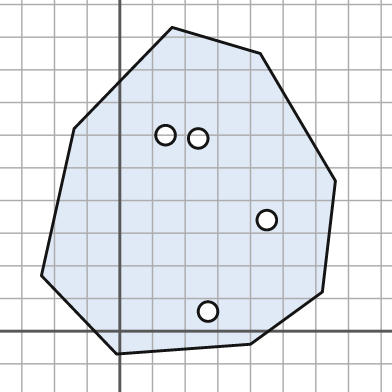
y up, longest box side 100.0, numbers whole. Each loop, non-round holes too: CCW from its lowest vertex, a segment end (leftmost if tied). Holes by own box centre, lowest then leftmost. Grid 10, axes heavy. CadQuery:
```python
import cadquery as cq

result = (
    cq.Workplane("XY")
    .moveTo(-1.0, -7.0)
    .lineTo(40.0, -4.0)
    .lineTo(62.0, 12.0)
    .lineTo(66.0, 46.0)
    .lineTo(43.0, 85.0)
    .lineTo(16.0, 93.0)
    .lineTo(-14.0, 62.0)
    .lineTo(-24.0, 17.0)
    .close()
    .moveTo(27.0, 6.0)
    .circle(3.0)
    .moveTo(45.0, 34.0)
    .circle(3.0)
    .moveTo(24.0, 59.0)
    .circle(3.0)
    .moveTo(14.0, 60.0)
    .circle(3.0)
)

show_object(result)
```